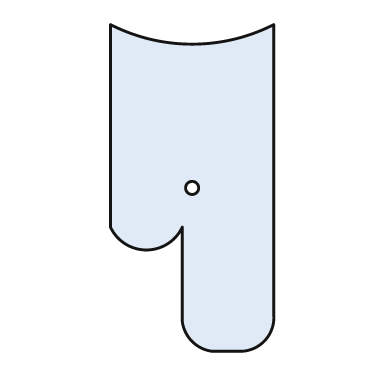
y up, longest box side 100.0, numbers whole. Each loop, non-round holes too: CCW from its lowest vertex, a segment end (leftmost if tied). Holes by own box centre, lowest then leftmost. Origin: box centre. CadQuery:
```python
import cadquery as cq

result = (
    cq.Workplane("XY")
    .moveTo(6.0, -50.0)
    .lineTo(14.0, -50.0)
    .threePointArc((22.0, -47.0), (25.0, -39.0))
    .lineTo(25.0, 50.0)
    .threePointArc((0.0, 44.0), (-25.0, 50.0))
    .lineTo(-25.0, -12.0)
    .threePointArc((-14.0, -19.0), (-3.0, -12.0))
    .lineTo(-3.0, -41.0)
    .threePointArc((0.0, -47.0), (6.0, -50.0))
    .close()
    .moveTo(0.0, 0.0)
    .circle(2.0)
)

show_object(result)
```